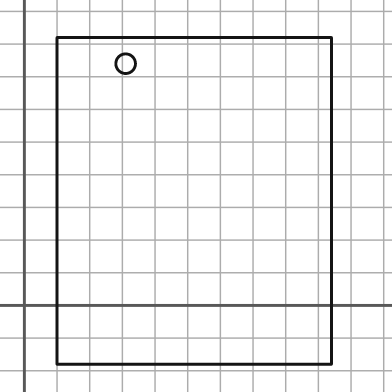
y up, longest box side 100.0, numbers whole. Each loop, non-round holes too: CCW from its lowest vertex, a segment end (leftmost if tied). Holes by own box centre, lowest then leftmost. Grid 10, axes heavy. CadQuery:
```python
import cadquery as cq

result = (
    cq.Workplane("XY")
    .moveTo(10.0, -18.0)
    .lineTo(94.0, -18.0)
    .lineTo(94.0, 82.0)
    .lineTo(10.0, 82.0)
    .close()
    .moveTo(31.0, 74.0)
    .circle(3.0)
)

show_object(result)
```